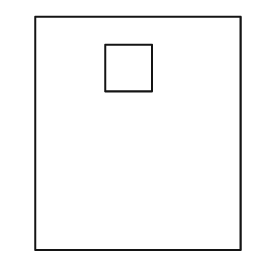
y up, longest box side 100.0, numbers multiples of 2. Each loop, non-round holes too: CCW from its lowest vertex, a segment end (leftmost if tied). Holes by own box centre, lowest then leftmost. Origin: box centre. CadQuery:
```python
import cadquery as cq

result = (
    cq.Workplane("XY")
    .moveTo(-44.0, -50.0)
    .lineTo(44.0, -50.0)
    .lineTo(44.0, 50.0)
    .lineTo(-44.0, 50.0)
    .close()
    .moveTo(-14.0, 18.0)
    .lineTo(6.0, 18.0)
    .lineTo(6.0, 38.0)
    .lineTo(-14.0, 38.0)
    .close()
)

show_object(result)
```